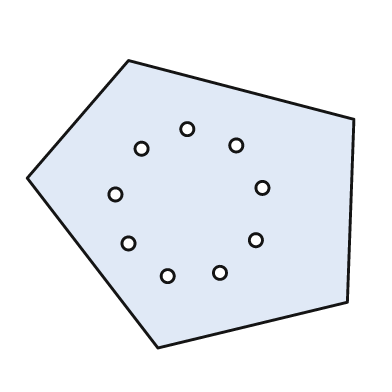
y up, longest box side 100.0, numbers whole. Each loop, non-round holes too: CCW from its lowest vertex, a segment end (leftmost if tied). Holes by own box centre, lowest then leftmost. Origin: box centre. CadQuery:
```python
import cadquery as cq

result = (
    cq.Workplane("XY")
    .moveTo(-10.0, -44.0)
    .lineTo(48.0, -30.0)
    .lineTo(50.0, 26.0)
    .lineTo(-19.0, 44.0)
    .lineTo(-50.0, 8.0)
    .close()
    .moveTo(-7.0, -22.0)
    .circle(2.0)
    .moveTo(9.0, -21.0)
    .circle(2.0)
    .moveTo(-19.0, -12.0)
    .circle(2.0)
    .moveTo(20.0, -11.0)
    .circle(2.0)
    .moveTo(-23.0, 3.0)
    .circle(2.0)
    .moveTo(22.0, 5.0)
    .circle(2.0)
    .moveTo(-15.0, 17.0)
    .circle(2.0)
    .moveTo(14.0, 18.0)
    .circle(2.0)
    .moveTo(-1.0, 23.0)
    .circle(2.0)
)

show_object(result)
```